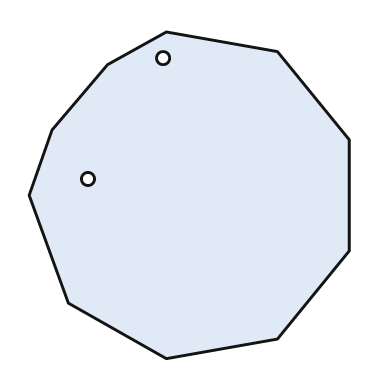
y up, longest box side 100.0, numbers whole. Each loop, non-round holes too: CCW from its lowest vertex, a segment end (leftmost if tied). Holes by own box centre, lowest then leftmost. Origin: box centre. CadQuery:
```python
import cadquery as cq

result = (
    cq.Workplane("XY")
    .moveTo(-7.0, -50.0)
    .lineTo(27.0, -44.0)
    .lineTo(49.0, -17.0)
    .lineTo(49.0, 17.0)
    .lineTo(27.0, 44.0)
    .lineTo(-7.0, 50.0)
    .lineTo(-25.0, 40.0)
    .lineTo(-42.0, 20.0)
    .lineTo(-49.0, 0.0)
    .lineTo(-37.0, -33.0)
    .close()
    .moveTo(-31.0, 5.0)
    .circle(2.0)
    .moveTo(-8.0, 42.0)
    .circle(2.0)
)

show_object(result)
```